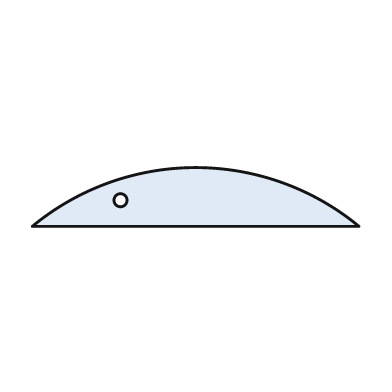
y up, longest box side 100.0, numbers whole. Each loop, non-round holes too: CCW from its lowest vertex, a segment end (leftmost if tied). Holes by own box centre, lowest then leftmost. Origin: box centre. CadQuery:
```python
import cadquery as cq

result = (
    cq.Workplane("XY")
    .moveTo(-50.0, -9.0)
    .lineTo(50.0, -9.0)
    .threePointArc((0.0, 9.0), (-50.0, -9.0))
    .close()
    .moveTo(-23.0, -1.0)
    .circle(2.0)
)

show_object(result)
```